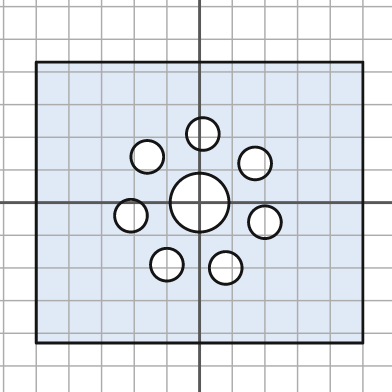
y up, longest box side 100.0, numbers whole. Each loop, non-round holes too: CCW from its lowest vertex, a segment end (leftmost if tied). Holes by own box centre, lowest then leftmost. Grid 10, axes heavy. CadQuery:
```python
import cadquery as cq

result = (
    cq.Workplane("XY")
    .moveTo(-50.0, -43.0)
    .lineTo(50.0, -43.0)
    .lineTo(50.0, 43.0)
    .lineTo(-50.0, 43.0)
    .close()
    .moveTo(8.0, -20.0)
    .circle(5.0)
    .moveTo(-10.0, -19.0)
    .circle(5.0)
    .moveTo(20.0, -6.0)
    .circle(5.0)
    .moveTo(-21.0, -4.0)
    .circle(5.0)
    .moveTo(0.0, 0.0)
    .circle(9.0)
    .moveTo(17.0, 12.0)
    .circle(5.0)
    .moveTo(-16.0, 14.0)
    .circle(5.0)
    .moveTo(1.0, 21.0)
    .circle(5.0)
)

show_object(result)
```